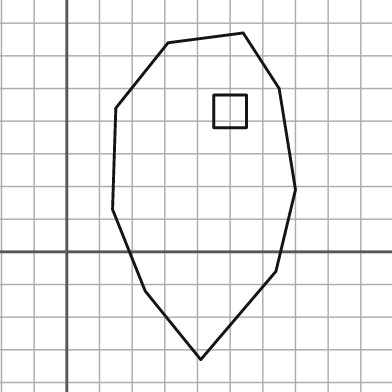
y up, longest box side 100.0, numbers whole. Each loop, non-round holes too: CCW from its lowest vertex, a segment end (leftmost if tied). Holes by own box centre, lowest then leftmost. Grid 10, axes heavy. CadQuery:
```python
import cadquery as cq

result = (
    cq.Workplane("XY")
    .moveTo(41.0, -33.0)
    .lineTo(64.0, -6.0)
    .lineTo(70.0, 19.0)
    .lineTo(65.0, 50.0)
    .lineTo(54.0, 67.0)
    .lineTo(31.0, 64.0)
    .lineTo(15.0, 44.0)
    .lineTo(14.0, 13.0)
    .lineTo(24.0, -12.0)
    .close()
    .moveTo(45.0, 38.0)
    .lineTo(55.0, 38.0)
    .lineTo(55.0, 48.0)
    .lineTo(45.0, 48.0)
    .close()
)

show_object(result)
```